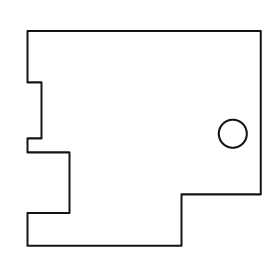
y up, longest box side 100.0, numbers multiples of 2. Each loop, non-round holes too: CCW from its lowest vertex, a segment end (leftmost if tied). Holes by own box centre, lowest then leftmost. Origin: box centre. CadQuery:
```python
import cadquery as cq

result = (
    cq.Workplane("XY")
    .moveTo(-50.0, -46.0)
    .lineTo(16.0, -46.0)
    .lineTo(16.0, -24.0)
    .lineTo(50.0, -24.0)
    .lineTo(50.0, 46.0)
    .lineTo(-50.0, 46.0)
    .lineTo(-50.0, 24.0)
    .lineTo(-44.0, 24.0)
    .lineTo(-44.0, 0.0)
    .lineTo(-50.0, 0.0)
    .lineTo(-50.0, -6.0)
    .lineTo(-32.0, -6.0)
    .lineTo(-32.0, -32.0)
    .lineTo(-50.0, -32.0)
    .close()
    .moveTo(38.0, 2.0)
    .circle(6.0)
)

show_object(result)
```